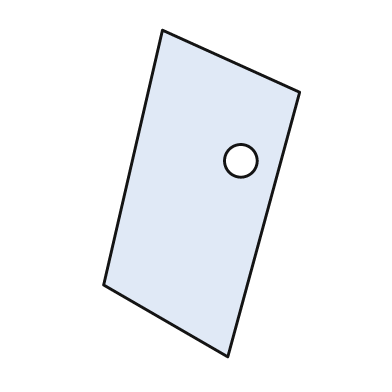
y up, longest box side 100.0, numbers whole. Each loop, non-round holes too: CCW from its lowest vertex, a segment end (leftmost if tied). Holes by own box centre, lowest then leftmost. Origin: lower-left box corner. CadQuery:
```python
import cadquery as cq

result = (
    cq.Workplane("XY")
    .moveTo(38.0, 0.0)
    .lineTo(60.0, 81.0)
    .lineTo(18.0, 100.0)
    .lineTo(0.0, 22.0)
    .close()
    .moveTo(42.0, 60.0)
    .circle(5.0)
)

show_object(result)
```